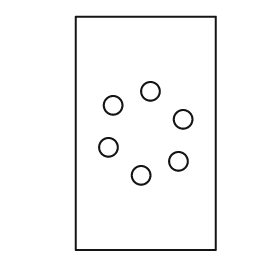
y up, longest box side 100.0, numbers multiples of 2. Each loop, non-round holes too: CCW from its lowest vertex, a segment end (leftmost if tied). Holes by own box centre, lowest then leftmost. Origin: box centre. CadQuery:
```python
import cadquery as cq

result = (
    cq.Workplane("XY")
    .moveTo(-30.0, -50.0)
    .lineTo(30.0, -50.0)
    .lineTo(30.0, 50.0)
    .lineTo(-30.0, 50.0)
    .close()
    .moveTo(-2.0, -18.0)
    .circle(4.0)
    .moveTo(14.0, -12.0)
    .circle(4.0)
    .moveTo(-16.0, -6.0)
    .circle(4.0)
    .moveTo(16.0, 6.0)
    .circle(4.0)
    .moveTo(-14.0, 12.0)
    .circle(4.0)
    .moveTo(2.0, 18.0)
    .circle(4.0)
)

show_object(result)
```